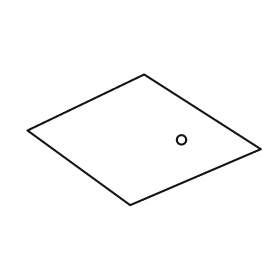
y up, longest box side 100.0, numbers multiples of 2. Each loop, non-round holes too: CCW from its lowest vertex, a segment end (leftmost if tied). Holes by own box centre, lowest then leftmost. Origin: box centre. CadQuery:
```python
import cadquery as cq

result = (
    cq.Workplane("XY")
    .moveTo(-6.0, -28.0)
    .lineTo(50.0, -4.0)
    .lineTo(0.0, 28.0)
    .lineTo(-50.0, 4.0)
    .close()
    .moveTo(16.0, 0.0)
    .circle(2.0)
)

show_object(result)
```